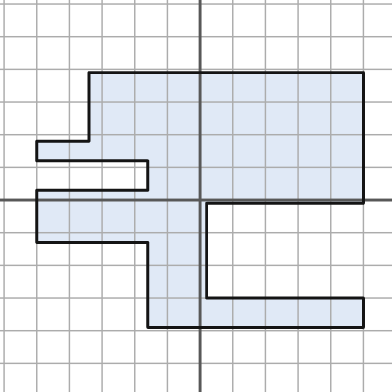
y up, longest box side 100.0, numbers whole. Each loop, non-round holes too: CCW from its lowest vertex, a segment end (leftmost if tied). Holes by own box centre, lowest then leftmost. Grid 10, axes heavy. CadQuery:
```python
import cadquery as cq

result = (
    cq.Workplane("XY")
    .moveTo(-16.0, -39.0)
    .lineTo(50.0, -39.0)
    .lineTo(50.0, -30.0)
    .lineTo(2.0, -30.0)
    .lineTo(2.0, -1.0)
    .lineTo(50.0, -1.0)
    .lineTo(50.0, 39.0)
    .lineTo(-34.0, 39.0)
    .lineTo(-34.0, 18.0)
    .lineTo(-50.0, 18.0)
    .lineTo(-50.0, 12.0)
    .lineTo(-16.0, 12.0)
    .lineTo(-16.0, 3.0)
    .lineTo(-50.0, 3.0)
    .lineTo(-50.0, -13.0)
    .lineTo(-16.0, -13.0)
    .close()
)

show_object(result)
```